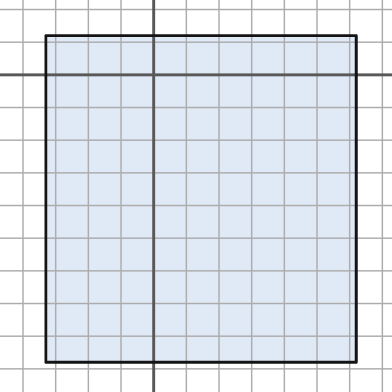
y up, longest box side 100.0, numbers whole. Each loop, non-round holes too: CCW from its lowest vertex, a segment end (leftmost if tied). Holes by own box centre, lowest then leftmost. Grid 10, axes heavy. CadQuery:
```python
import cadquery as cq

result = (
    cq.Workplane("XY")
    .moveTo(-33.0, -88.0)
    .lineTo(62.0, -88.0)
    .lineTo(62.0, 12.0)
    .lineTo(-33.0, 12.0)
    .close()
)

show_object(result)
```